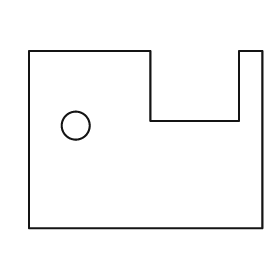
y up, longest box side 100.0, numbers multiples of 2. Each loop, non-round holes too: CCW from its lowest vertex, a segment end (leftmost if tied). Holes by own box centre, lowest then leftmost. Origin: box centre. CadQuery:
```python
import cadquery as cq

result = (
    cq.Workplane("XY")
    .moveTo(-50.0, -38.0)
    .lineTo(50.0, -38.0)
    .lineTo(50.0, 38.0)
    .lineTo(40.0, 38.0)
    .lineTo(40.0, 8.0)
    .lineTo(2.0, 8.0)
    .lineTo(2.0, 38.0)
    .lineTo(-50.0, 38.0)
    .close()
    .moveTo(-30.0, 6.0)
    .circle(6.0)
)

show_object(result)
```